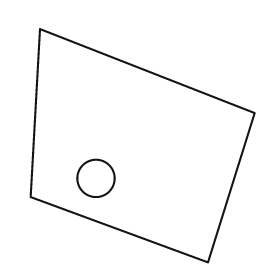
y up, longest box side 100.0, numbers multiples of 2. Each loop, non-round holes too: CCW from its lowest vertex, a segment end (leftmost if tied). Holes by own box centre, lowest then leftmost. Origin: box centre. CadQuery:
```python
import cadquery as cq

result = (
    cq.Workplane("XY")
    .moveTo(28.0, -50.0)
    .lineTo(48.0, 14.0)
    .lineTo(-44.0, 50.0)
    .lineTo(-48.0, -22.0)
    .close()
    .moveTo(-20.0, -14.0)
    .circle(8.0)
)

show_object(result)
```